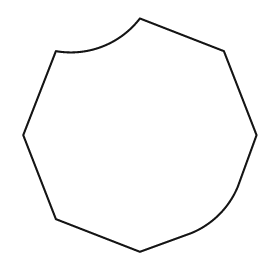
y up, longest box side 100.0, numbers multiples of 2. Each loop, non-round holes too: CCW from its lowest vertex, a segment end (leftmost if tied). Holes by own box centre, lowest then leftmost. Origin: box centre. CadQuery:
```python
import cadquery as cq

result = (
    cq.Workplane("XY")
    .moveTo(0.0, -50.0)
    .lineTo(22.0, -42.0)
    .threePointArc((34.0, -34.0), (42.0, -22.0))
    .lineTo(50.0, 0.0)
    .lineTo(36.0, 36.0)
    .lineTo(0.0, 50.0)
    .threePointArc((-16.0, 38.0), (-36.0, 36.0))
    .lineTo(-50.0, 0.0)
    .lineTo(-36.0, -36.0)
    .close()
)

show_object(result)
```